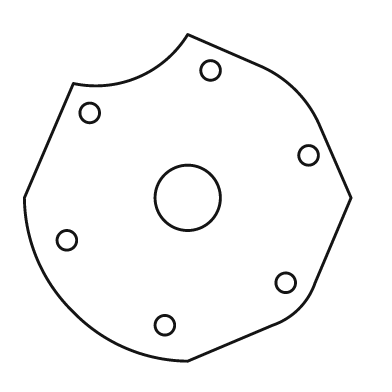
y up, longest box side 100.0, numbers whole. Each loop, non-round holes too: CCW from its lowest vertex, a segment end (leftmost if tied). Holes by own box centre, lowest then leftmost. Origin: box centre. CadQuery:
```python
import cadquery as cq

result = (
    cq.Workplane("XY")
    .moveTo(0.0, -50.0)
    .lineTo(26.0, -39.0)
    .threePointArc((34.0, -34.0), (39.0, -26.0))
    .lineTo(50.0, 0.0)
    .lineTo(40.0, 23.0)
    .threePointArc((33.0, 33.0), (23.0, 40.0))
    .lineTo(0.0, 50.0)
    .threePointArc((-15.0, 37.0), (-35.0, 35.0))
    .lineTo(-50.0, 0.0)
    .threePointArc((-46.0, -19.0), (-35.0, -35.0))
    .threePointArc((-19.0, -46.0), (0.0, -50.0))
    .close()
    .moveTo(-7.0, -39.0)
    .circle(3.0)
    .moveTo(30.0, -26.0)
    .circle(3.0)
    .moveTo(-37.0, -13.0)
    .circle(3.0)
    .moveTo(0.0, 0.0)
    .circle(10.0)
    .moveTo(37.0, 13.0)
    .circle(3.0)
    .moveTo(-30.0, 26.0)
    .circle(3.0)
    .moveTo(7.0, 39.0)
    .circle(3.0)
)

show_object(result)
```